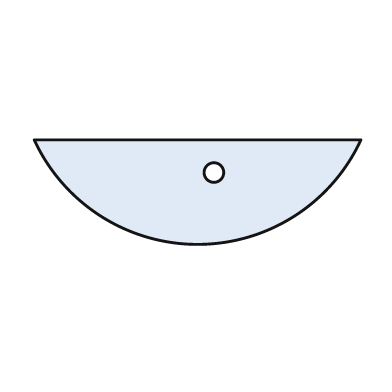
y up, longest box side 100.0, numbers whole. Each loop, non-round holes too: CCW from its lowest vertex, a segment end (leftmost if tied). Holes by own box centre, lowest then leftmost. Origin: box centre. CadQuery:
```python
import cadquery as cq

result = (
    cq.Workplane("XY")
    .moveTo(-50.0, 16.0)
    .threePointArc((0.0, -16.0), (50.0, 16.0))
    .close()
    .moveTo(5.0, 6.0)
    .circle(3.0)
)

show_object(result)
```